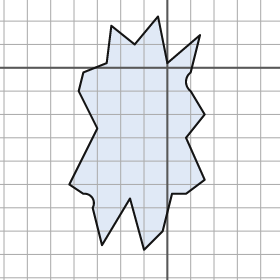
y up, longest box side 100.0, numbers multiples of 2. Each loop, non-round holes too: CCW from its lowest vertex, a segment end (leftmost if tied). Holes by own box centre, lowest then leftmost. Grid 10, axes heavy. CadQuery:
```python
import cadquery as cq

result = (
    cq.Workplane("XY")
    .moveTo(-10.0, -78.0)
    .lineTo(-2.0, -70.0)
    .lineTo(2.0, -54.0)
    .lineTo(8.0, -54.0)
    .lineTo(16.0, -48.0)
    .lineTo(8.0, -30.0)
    .lineTo(16.0, -20.0)
    .lineTo(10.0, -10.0)
    .threePointArc((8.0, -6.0), (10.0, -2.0))
    .lineTo(14.0, 14.0)
    .lineTo(0.0, 2.0)
    .lineTo(-4.0, 22.0)
    .lineTo(-14.0, 10.0)
    .lineTo(-24.0, 18.0)
    .lineTo(-26.0, 2.0)
    .lineTo(-36.0, -2.0)
    .lineTo(-38.0, -10.0)
    .lineTo(-30.0, -26.0)
    .lineTo(-42.0, -50.0)
    .lineTo(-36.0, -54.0)
    .threePointArc((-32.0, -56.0), (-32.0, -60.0))
    .lineTo(-28.0, -76.0)
    .lineTo(-16.0, -56.0)
    .close()
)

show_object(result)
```